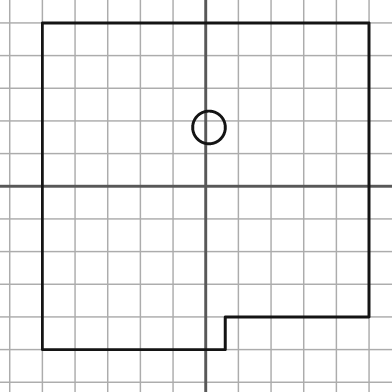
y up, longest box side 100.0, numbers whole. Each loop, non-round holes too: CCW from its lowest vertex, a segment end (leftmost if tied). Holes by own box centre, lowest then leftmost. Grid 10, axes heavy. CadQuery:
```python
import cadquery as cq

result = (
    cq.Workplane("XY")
    .moveTo(-50.0, -50.0)
    .lineTo(6.0, -50.0)
    .lineTo(6.0, -40.0)
    .lineTo(50.0, -40.0)
    .lineTo(50.0, 50.0)
    .lineTo(-50.0, 50.0)
    .close()
    .moveTo(1.0, 18.0)
    .circle(5.0)
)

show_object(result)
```